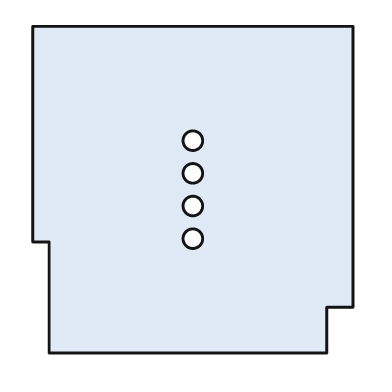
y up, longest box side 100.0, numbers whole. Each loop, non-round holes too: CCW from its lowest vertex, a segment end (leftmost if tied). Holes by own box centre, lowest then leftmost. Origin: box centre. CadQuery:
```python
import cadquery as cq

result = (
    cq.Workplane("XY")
    .moveTo(-44.0, -50.0)
    .lineTo(41.0, -50.0)
    .lineTo(41.0, -36.0)
    .lineTo(49.0, -36.0)
    .lineTo(49.0, 50.0)
    .lineTo(-49.0, 50.0)
    .lineTo(-49.0, -16.0)
    .lineTo(-44.0, -16.0)
    .close()
    .moveTo(0.0, -15.0)
    .circle(3.0)
    .moveTo(0.0, -5.0)
    .circle(3.0)
    .moveTo(0.0, 5.0)
    .circle(3.0)
    .moveTo(0.0, 15.0)
    .circle(3.0)
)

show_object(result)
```